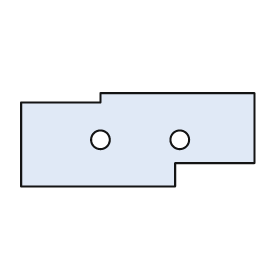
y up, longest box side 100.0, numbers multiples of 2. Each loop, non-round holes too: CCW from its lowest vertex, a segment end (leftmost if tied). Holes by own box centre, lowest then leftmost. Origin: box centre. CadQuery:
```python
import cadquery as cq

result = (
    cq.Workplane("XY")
    .moveTo(-50.0, -20.0)
    .lineTo(16.0, -20.0)
    .lineTo(16.0, -10.0)
    .lineTo(50.0, -10.0)
    .lineTo(50.0, 20.0)
    .lineTo(-16.0, 20.0)
    .lineTo(-16.0, 16.0)
    .lineTo(-50.0, 16.0)
    .close()
    .moveTo(-16.0, 0.0)
    .circle(4.0)
    .moveTo(18.0, 0.0)
    .circle(4.0)
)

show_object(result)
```